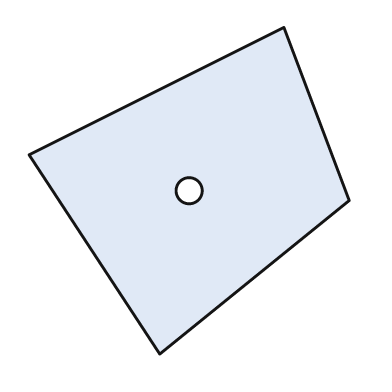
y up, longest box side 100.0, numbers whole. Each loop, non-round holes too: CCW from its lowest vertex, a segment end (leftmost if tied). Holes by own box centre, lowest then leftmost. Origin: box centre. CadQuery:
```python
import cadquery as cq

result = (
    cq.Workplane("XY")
    .moveTo(-9.0, -50.0)
    .lineTo(49.0, -3.0)
    .lineTo(29.0, 50.0)
    .lineTo(-49.0, 11.0)
    .close()
    .moveTo(0.0, 0.0)
    .circle(4.0)
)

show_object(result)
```